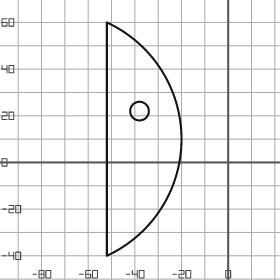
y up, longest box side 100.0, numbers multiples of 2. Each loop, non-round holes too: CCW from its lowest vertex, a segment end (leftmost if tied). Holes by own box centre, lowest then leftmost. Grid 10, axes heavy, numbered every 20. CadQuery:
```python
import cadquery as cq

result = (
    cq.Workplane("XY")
    .moveTo(-52.0, -40.0)
    .threePointArc((-20.0, 10.0), (-52.0, 60.0))
    .close()
    .moveTo(-38.0, 22.0)
    .circle(4.0)
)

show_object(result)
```